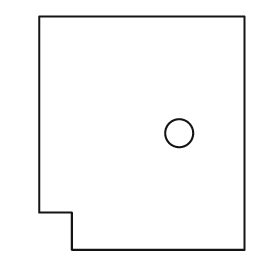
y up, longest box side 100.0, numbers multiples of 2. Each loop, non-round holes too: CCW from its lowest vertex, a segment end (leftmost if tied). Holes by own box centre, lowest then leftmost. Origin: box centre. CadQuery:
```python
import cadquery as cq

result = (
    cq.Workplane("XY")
    .moveTo(-30.0, -50.0)
    .lineTo(44.0, -50.0)
    .lineTo(44.0, 50.0)
    .lineTo(-44.0, 50.0)
    .lineTo(-44.0, -34.0)
    .lineTo(-30.0, -34.0)
    .close()
    .moveTo(16.0, 0.0)
    .circle(6.0)
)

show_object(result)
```